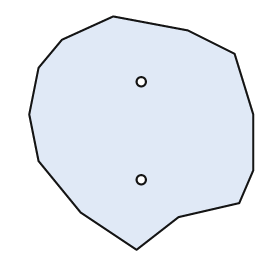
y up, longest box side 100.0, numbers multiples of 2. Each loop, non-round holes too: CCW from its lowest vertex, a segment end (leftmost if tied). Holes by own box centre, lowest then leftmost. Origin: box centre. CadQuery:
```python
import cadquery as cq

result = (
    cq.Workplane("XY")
    .moveTo(-2.0, -50.0)
    .lineTo(16.0, -36.0)
    .lineTo(42.0, -30.0)
    .lineTo(48.0, -16.0)
    .lineTo(48.0, 8.0)
    .lineTo(40.0, 34.0)
    .lineTo(20.0, 44.0)
    .lineTo(-12.0, 50.0)
    .lineTo(-34.0, 40.0)
    .lineTo(-44.0, 28.0)
    .lineTo(-48.0, 8.0)
    .lineTo(-44.0, -12.0)
    .lineTo(-26.0, -34.0)
    .close()
    .moveTo(0.0, -20.0)
    .circle(2.0)
    .moveTo(0.0, 22.0)
    .circle(2.0)
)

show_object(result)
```